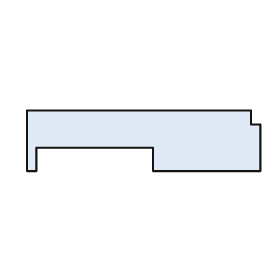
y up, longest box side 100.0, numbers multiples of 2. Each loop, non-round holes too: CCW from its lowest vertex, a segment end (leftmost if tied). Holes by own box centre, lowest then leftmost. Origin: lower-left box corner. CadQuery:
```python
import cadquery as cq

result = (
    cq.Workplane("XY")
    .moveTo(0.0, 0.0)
    .lineTo(4.0, 0.0)
    .lineTo(4.0, 10.0)
    .lineTo(54.0, 10.0)
    .lineTo(54.0, 0.0)
    .lineTo(100.0, 0.0)
    .lineTo(100.0, 20.0)
    .lineTo(96.0, 20.0)
    .lineTo(96.0, 26.0)
    .lineTo(0.0, 26.0)
    .close()
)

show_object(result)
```